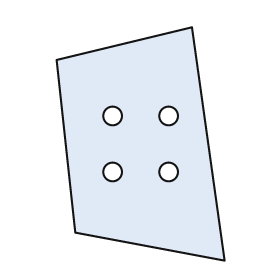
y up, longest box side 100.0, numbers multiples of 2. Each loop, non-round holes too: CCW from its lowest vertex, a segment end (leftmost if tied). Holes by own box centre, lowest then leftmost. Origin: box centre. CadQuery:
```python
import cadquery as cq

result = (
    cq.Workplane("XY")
    .moveTo(36.0, -50.0)
    .lineTo(22.0, 50.0)
    .lineTo(-36.0, 36.0)
    .lineTo(-28.0, -38.0)
    .close()
    .moveTo(-12.0, -12.0)
    .circle(4.0)
    .moveTo(12.0, -12.0)
    .circle(4.0)
    .moveTo(-12.0, 12.0)
    .circle(4.0)
    .moveTo(12.0, 12.0)
    .circle(4.0)
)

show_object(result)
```